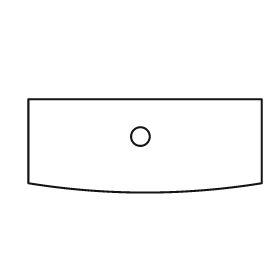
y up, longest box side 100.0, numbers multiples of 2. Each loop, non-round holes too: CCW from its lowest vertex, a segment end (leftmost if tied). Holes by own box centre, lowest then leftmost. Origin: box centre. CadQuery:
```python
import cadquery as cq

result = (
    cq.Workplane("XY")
    .moveTo(-50.0, -16.0)
    .threePointArc((0.0, -20.0), (50.0, -16.0))
    .lineTo(50.0, 20.0)
    .lineTo(-50.0, 20.0)
    .close()
    .moveTo(-2.0, 4.0)
    .circle(4.0)
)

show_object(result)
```